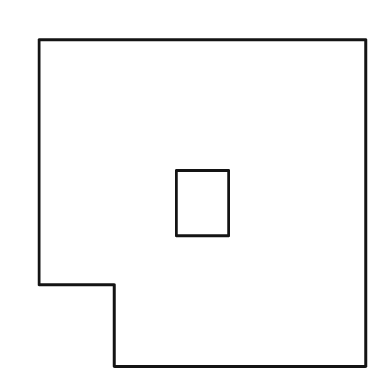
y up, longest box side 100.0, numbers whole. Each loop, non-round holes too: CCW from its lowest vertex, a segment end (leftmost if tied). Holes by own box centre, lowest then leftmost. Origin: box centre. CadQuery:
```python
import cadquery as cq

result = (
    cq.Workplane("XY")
    .moveTo(-27.0, -50.0)
    .lineTo(50.0, -50.0)
    .lineTo(50.0, 50.0)
    .lineTo(-50.0, 50.0)
    .lineTo(-50.0, -25.0)
    .lineTo(-27.0, -25.0)
    .close()
    .moveTo(-8.0, -10.0)
    .lineTo(8.0, -10.0)
    .lineTo(8.0, 10.0)
    .lineTo(-8.0, 10.0)
    .close()
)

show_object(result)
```